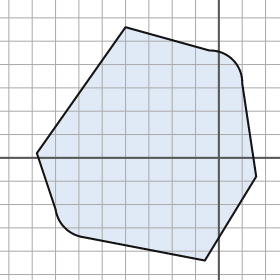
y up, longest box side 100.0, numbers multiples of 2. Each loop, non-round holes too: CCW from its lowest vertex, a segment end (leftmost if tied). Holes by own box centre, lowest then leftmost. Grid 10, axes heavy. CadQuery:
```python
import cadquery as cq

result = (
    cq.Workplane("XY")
    .moveTo(-6.0, -44.0)
    .lineTo(16.0, -8.0)
    .lineTo(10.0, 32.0)
    .threePointArc((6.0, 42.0), (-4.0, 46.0))
    .lineTo(-40.0, 56.0)
    .lineTo(-78.0, 2.0)
    .lineTo(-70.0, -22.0)
    .threePointArc((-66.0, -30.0), (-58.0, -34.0))
    .close()
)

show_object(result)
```